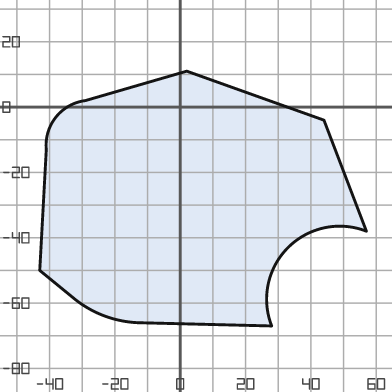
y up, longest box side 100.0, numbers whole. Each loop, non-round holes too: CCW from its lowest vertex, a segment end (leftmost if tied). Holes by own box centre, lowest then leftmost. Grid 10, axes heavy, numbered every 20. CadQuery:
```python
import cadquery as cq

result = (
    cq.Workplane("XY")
    .moveTo(28.0, -67.0)
    .threePointArc((33.0, -43.0), (57.0, -38.0))
    .lineTo(44.0, -4.0)
    .lineTo(2.0, 11.0)
    .lineTo(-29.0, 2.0)
    .threePointArc((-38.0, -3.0), (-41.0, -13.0))
    .lineTo(-43.0, -50.0)
    .lineTo(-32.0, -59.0)
    .threePointArc((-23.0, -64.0), (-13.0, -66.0))
    .close()
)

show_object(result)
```